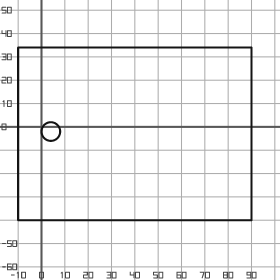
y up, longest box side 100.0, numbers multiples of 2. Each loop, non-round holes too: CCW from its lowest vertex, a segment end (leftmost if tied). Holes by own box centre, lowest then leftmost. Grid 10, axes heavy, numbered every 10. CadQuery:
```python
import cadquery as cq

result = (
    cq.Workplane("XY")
    .moveTo(-10.0, -40.0)
    .lineTo(90.0, -40.0)
    .lineTo(90.0, 34.0)
    .lineTo(-10.0, 34.0)
    .close()
    .moveTo(4.0, -2.0)
    .circle(4.0)
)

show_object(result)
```